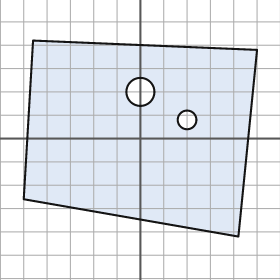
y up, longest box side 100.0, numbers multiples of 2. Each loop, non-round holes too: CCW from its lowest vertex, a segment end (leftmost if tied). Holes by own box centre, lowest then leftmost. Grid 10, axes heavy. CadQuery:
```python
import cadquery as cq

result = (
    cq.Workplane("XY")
    .moveTo(42.0, -42.0)
    .lineTo(50.0, 38.0)
    .lineTo(-46.0, 42.0)
    .lineTo(-50.0, -26.0)
    .close()
    .moveTo(20.0, 8.0)
    .circle(4.0)
    .moveTo(0.0, 20.0)
    .circle(6.0)
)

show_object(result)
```